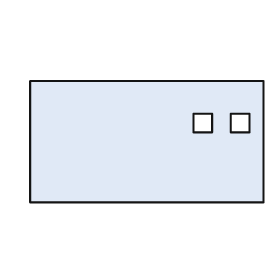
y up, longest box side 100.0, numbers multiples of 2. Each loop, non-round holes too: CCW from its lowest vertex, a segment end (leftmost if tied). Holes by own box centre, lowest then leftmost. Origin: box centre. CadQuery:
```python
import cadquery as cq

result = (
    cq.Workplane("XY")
    .moveTo(-50.0, -26.0)
    .lineTo(50.0, -26.0)
    .lineTo(50.0, 26.0)
    .lineTo(-50.0, 26.0)
    .close()
    .moveTo(20.0, 4.0)
    .lineTo(28.0, 4.0)
    .lineTo(28.0, 12.0)
    .lineTo(20.0, 12.0)
    .close()
    .moveTo(36.0, 4.0)
    .lineTo(44.0, 4.0)
    .lineTo(44.0, 12.0)
    .lineTo(36.0, 12.0)
    .close()
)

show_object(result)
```